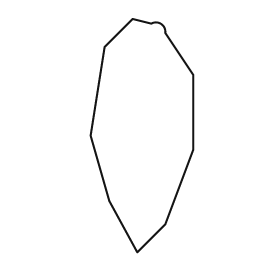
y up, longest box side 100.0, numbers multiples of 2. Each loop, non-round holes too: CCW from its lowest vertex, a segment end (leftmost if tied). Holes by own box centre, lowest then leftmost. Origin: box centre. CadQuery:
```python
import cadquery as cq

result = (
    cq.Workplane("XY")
    .moveTo(-2.0, -50.0)
    .lineTo(10.0, -38.0)
    .lineTo(22.0, -6.0)
    .lineTo(22.0, 26.0)
    .lineTo(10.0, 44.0)
    .threePointArc((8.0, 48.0), (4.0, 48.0))
    .lineTo(-4.0, 50.0)
    .lineTo(-16.0, 38.0)
    .lineTo(-22.0, 0.0)
    .lineTo(-14.0, -28.0)
    .close()
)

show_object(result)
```